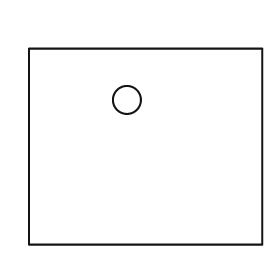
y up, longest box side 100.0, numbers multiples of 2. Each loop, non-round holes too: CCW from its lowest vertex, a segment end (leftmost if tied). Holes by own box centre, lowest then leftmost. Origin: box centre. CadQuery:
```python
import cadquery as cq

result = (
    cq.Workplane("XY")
    .moveTo(-50.0, -42.0)
    .lineTo(50.0, -42.0)
    .lineTo(50.0, 42.0)
    .lineTo(-50.0, 42.0)
    .close()
    .moveTo(-8.0, 20.0)
    .circle(6.0)
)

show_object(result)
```